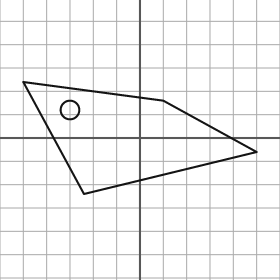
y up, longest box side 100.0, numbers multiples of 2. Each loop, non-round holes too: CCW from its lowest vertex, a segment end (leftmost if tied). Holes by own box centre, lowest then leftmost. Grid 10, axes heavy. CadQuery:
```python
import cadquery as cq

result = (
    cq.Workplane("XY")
    .moveTo(-24.0, -24.0)
    .lineTo(50.0, -6.0)
    .lineTo(10.0, 16.0)
    .lineTo(-50.0, 24.0)
    .close()
    .moveTo(-30.0, 12.0)
    .circle(4.0)
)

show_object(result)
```